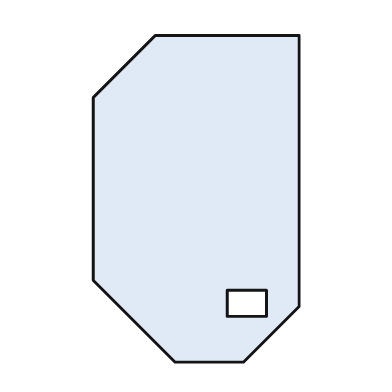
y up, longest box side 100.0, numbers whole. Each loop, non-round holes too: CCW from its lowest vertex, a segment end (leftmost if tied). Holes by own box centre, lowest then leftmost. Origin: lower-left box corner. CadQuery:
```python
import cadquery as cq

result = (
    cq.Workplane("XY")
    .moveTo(25.0, 0.0)
    .lineTo(46.0, 0.0)
    .lineTo(63.0, 17.0)
    .lineTo(63.0, 100.0)
    .lineTo(19.0, 100.0)
    .lineTo(0.0, 81.0)
    .lineTo(0.0, 25.0)
    .close()
    .moveTo(41.0, 14.0)
    .lineTo(53.0, 14.0)
    .lineTo(53.0, 22.0)
    .lineTo(41.0, 22.0)
    .close()
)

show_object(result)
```